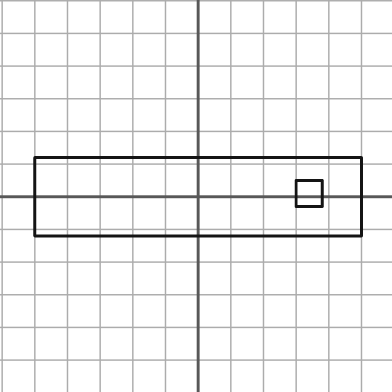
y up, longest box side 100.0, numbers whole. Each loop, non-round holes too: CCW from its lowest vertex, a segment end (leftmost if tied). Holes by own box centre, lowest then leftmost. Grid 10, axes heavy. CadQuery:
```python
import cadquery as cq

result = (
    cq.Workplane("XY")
    .moveTo(-50.0, -12.0)
    .lineTo(50.0, -12.0)
    .lineTo(50.0, 12.0)
    .lineTo(-50.0, 12.0)
    .close()
    .moveTo(30.0, -3.0)
    .lineTo(38.0, -3.0)
    .lineTo(38.0, 5.0)
    .lineTo(30.0, 5.0)
    .close()
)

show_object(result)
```